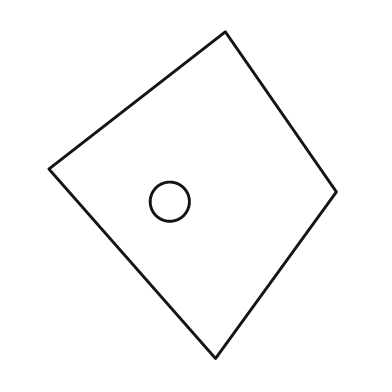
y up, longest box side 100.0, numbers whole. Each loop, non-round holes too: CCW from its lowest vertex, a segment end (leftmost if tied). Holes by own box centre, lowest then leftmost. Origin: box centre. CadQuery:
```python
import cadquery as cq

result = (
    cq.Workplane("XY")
    .moveTo(7.0, -50.0)
    .lineTo(44.0, 1.0)
    .lineTo(10.0, 50.0)
    .lineTo(-44.0, 8.0)
    .close()
    .moveTo(-7.0, -2.0)
    .circle(6.0)
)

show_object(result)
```